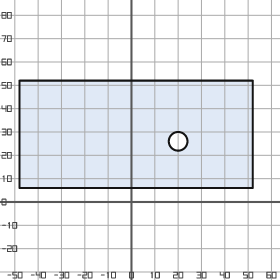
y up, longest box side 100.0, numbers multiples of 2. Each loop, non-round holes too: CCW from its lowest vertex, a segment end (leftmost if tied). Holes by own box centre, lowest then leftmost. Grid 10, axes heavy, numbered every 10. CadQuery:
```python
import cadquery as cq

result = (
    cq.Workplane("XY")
    .moveTo(-48.0, 6.0)
    .lineTo(52.0, 6.0)
    .lineTo(52.0, 52.0)
    .lineTo(-48.0, 52.0)
    .close()
    .moveTo(20.0, 26.0)
    .circle(4.0)
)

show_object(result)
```